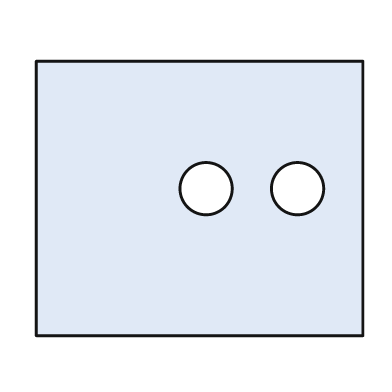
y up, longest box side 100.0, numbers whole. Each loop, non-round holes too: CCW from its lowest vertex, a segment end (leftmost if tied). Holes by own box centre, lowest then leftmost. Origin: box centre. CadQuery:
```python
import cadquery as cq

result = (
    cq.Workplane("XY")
    .moveTo(-50.0, -42.0)
    .lineTo(50.0, -42.0)
    .lineTo(50.0, 42.0)
    .lineTo(-50.0, 42.0)
    .close()
    .moveTo(2.0, 3.0)
    .circle(8.0)
    .moveTo(30.0, 3.0)
    .circle(8.0)
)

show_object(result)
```